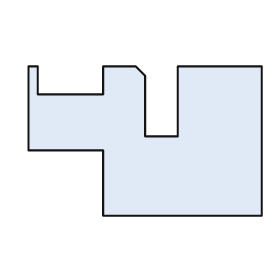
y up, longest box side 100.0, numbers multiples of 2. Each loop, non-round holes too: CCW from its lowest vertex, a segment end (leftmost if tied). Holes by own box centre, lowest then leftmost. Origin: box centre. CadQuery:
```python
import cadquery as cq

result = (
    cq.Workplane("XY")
    .moveTo(-18.0, -32.0)
    .lineTo(50.0, -32.0)
    .lineTo(50.0, 32.0)
    .lineTo(14.0, 32.0)
    .lineTo(14.0, 2.0)
    .lineTo(0.0, 2.0)
    .lineTo(0.0, 28.0)
    .lineTo(-4.0, 32.0)
    .lineTo(-18.0, 32.0)
    .lineTo(-18.0, 20.0)
    .lineTo(-46.0, 20.0)
    .lineTo(-46.0, 32.0)
    .lineTo(-50.0, 32.0)
    .lineTo(-50.0, -4.0)
    .lineTo(-18.0, -4.0)
    .close()
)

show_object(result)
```